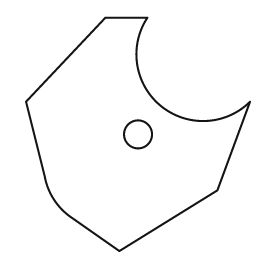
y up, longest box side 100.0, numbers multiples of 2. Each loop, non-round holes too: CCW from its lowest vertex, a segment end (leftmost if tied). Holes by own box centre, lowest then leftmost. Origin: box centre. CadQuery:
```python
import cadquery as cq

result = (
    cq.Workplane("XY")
    .moveTo(-8.0, -50.0)
    .lineTo(34.0, -24.0)
    .lineTo(48.0, 14.0)
    .threePointArc((10.0, 12.0), (4.0, 50.0))
    .lineTo(-14.0, 50.0)
    .lineTo(-48.0, 14.0)
    .lineTo(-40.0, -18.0)
    .threePointArc((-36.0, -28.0), (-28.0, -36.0))
    .close()
    .moveTo(0.0, 0.0)
    .circle(6.0)
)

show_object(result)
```